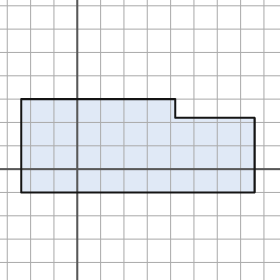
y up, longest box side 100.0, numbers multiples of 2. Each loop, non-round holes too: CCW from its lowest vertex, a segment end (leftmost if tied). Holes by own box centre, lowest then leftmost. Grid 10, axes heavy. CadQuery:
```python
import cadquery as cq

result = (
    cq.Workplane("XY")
    .moveTo(-24.0, -10.0)
    .lineTo(76.0, -10.0)
    .lineTo(76.0, 22.0)
    .lineTo(42.0, 22.0)
    .lineTo(42.0, 30.0)
    .lineTo(-24.0, 30.0)
    .close()
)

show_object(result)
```